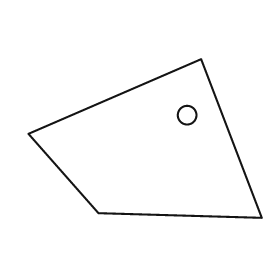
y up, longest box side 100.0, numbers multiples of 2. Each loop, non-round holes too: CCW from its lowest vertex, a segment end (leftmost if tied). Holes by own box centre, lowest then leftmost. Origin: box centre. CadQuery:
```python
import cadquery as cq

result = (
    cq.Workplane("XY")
    .moveTo(50.0, -34.0)
    .lineTo(24.0, 34.0)
    .lineTo(-50.0, 2.0)
    .lineTo(-20.0, -32.0)
    .close()
    .moveTo(18.0, 10.0)
    .circle(4.0)
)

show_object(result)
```